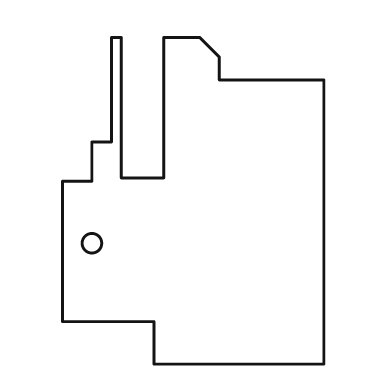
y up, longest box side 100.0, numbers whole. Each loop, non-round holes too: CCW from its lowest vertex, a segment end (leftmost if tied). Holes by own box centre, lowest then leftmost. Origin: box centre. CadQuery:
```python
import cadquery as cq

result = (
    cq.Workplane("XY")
    .moveTo(-12.0, -50.0)
    .lineTo(40.0, -50.0)
    .lineTo(40.0, 37.0)
    .lineTo(8.0, 37.0)
    .lineTo(8.0, 44.0)
    .lineTo(2.0, 50.0)
    .lineTo(-9.0, 50.0)
    .lineTo(-9.0, 7.0)
    .lineTo(-22.0, 7.0)
    .lineTo(-22.0, 50.0)
    .lineTo(-25.0, 50.0)
    .lineTo(-25.0, 18.0)
    .lineTo(-31.0, 18.0)
    .lineTo(-31.0, 6.0)
    .lineTo(-40.0, 6.0)
    .lineTo(-40.0, -37.0)
    .lineTo(-12.0, -37.0)
    .close()
    .moveTo(-31.0, -13.0)
    .circle(3.0)
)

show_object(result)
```